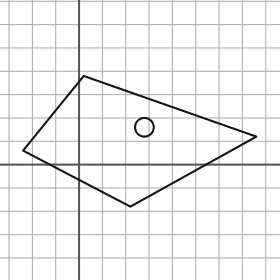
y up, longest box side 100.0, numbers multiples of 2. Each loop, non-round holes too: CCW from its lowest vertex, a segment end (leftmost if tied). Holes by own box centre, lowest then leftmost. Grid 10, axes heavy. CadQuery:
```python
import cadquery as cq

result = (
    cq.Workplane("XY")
    .moveTo(22.0, -18.0)
    .lineTo(76.0, 12.0)
    .lineTo(2.0, 38.0)
    .lineTo(-24.0, 6.0)
    .close()
    .moveTo(28.0, 16.0)
    .circle(4.0)
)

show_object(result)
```